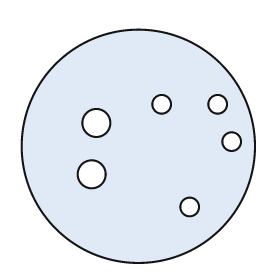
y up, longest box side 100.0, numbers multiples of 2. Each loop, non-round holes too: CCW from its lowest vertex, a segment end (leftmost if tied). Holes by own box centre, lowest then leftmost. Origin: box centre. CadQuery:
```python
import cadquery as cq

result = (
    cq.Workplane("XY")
    .moveTo(0.0, 0.0)
    .circle(50.0)
    .moveTo(22.0, -26.0)
    .circle(4.0)
    .moveTo(-20.0, -12.0)
    .circle(6.0)
    .moveTo(40.0, 2.0)
    .circle(4.0)
    .moveTo(-18.0, 10.0)
    .circle(6.0)
    .moveTo(10.0, 18.0)
    .circle(4.0)
    .moveTo(34.0, 18.0)
    .circle(4.0)
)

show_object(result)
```